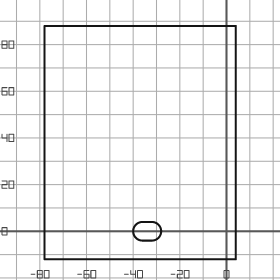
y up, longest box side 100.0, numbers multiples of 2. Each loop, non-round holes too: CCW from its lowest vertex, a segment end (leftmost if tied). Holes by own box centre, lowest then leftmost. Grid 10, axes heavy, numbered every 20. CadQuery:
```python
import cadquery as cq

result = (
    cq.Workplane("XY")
    .moveTo(-78.0, -12.0)
    .lineTo(4.0, -12.0)
    .lineTo(4.0, 88.0)
    .lineTo(-78.0, 88.0)
    .close()
    .moveTo(-36.0, -4.0)
    .lineTo(-32.0, -4.0)
    .threePointArc((-28.0, 0.0), (-32.0, 4.0))
    .lineTo(-36.0, 4.0)
    .threePointArc((-40.0, 0.0), (-36.0, -4.0))
    .close()
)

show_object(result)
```